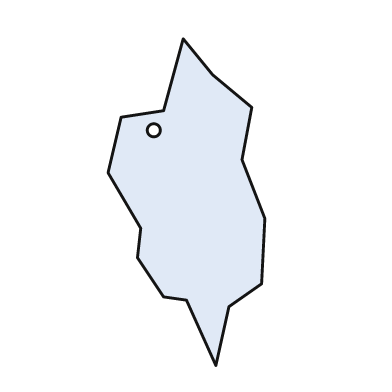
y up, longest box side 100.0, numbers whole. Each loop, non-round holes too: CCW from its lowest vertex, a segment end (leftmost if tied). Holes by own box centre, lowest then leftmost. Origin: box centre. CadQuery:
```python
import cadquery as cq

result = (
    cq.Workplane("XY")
    .moveTo(9.0, -50.0)
    .lineTo(13.0, -32.0)
    .lineTo(23.0, -25.0)
    .lineTo(24.0, -5.0)
    .lineTo(17.0, 13.0)
    .lineTo(20.0, 29.0)
    .lineTo(8.0, 39.0)
    .lineTo(-1.0, 50.0)
    .lineTo(-7.0, 28.0)
    .lineTo(-20.0, 26.0)
    .lineTo(-24.0, 9.0)
    .lineTo(-14.0, -8.0)
    .lineTo(-15.0, -17.0)
    .lineTo(-7.0, -29.0)
    .lineTo(0.0, -30.0)
    .close()
    .moveTo(-10.0, 22.0)
    .circle(2.0)
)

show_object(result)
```